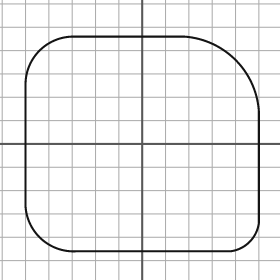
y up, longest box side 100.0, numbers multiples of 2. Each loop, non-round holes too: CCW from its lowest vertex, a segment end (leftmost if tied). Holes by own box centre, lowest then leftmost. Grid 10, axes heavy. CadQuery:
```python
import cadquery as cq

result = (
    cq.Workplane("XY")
    .moveTo(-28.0, -46.0)
    .lineTo(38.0, -46.0)
    .threePointArc((46.0, -42.0), (50.0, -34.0))
    .lineTo(50.0, 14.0)
    .threePointArc((40.0, 36.0), (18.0, 46.0))
    .lineTo(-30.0, 46.0)
    .threePointArc((-44.0, 40.0), (-50.0, 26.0))
    .lineTo(-50.0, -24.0)
    .threePointArc((-44.0, -40.0), (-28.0, -46.0))
    .close()
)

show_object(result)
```